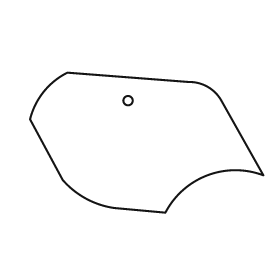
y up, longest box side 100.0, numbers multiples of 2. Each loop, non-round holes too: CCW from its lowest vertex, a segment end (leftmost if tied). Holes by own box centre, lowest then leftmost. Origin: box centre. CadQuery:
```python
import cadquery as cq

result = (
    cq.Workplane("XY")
    .moveTo(8.0, -30.0)
    .threePointArc((26.0, -14.0), (50.0, -14.0))
    .lineTo(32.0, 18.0)
    .threePointArc((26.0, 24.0), (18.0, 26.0))
    .lineTo(-34.0, 30.0)
    .threePointArc((-44.0, 22.0), (-50.0, 10.0))
    .lineTo(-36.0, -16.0)
    .threePointArc((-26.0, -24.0), (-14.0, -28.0))
    .close()
    .moveTo(-8.0, 18.0)
    .circle(2.0)
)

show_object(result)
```